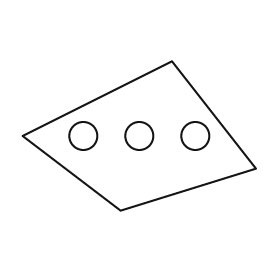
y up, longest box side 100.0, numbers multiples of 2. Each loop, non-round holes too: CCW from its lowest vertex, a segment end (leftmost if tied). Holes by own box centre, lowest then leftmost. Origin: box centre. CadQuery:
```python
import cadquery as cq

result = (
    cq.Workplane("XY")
    .moveTo(-8.0, -32.0)
    .lineTo(50.0, -14.0)
    .lineTo(14.0, 32.0)
    .lineTo(-50.0, 0.0)
    .close()
    .moveTo(-24.0, 0.0)
    .circle(6.0)
    .moveTo(0.0, 0.0)
    .circle(6.0)
    .moveTo(24.0, 0.0)
    .circle(6.0)
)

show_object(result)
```